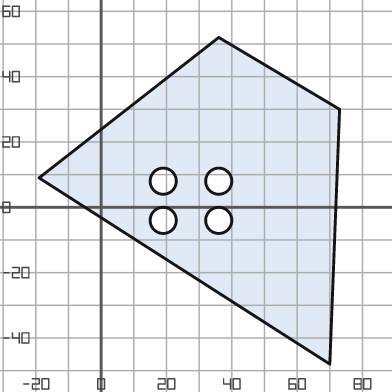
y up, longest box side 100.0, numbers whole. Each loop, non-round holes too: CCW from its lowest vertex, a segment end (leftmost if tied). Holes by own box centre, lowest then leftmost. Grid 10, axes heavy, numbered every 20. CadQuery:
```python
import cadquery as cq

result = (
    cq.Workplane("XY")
    .moveTo(70.0, -48.0)
    .lineTo(73.0, 30.0)
    .lineTo(36.0, 52.0)
    .lineTo(-19.0, 9.0)
    .close()
    .moveTo(19.0, -4.0)
    .circle(4.0)
    .moveTo(36.0, -4.0)
    .circle(4.0)
    .moveTo(19.0, 8.0)
    .circle(4.0)
    .moveTo(36.0, 8.0)
    .circle(4.0)
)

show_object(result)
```